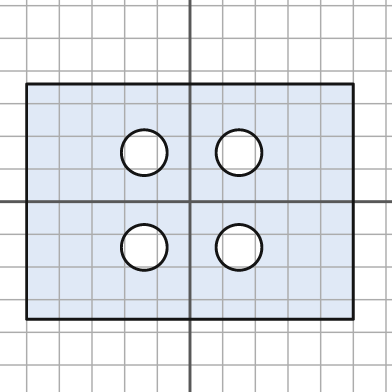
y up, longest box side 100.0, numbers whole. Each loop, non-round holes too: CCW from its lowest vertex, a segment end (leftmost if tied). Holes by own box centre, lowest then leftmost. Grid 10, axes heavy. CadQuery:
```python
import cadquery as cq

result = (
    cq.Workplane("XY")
    .moveTo(-50.0, -36.0)
    .lineTo(50.0, -36.0)
    .lineTo(50.0, 36.0)
    .lineTo(-50.0, 36.0)
    .close()
    .moveTo(-14.0, -14.0)
    .circle(7.0)
    .moveTo(15.0, -14.0)
    .circle(7.0)
    .moveTo(-14.0, 15.0)
    .circle(7.0)
    .moveTo(15.0, 15.0)
    .circle(7.0)
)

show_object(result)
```